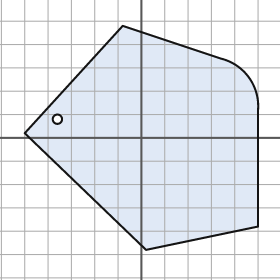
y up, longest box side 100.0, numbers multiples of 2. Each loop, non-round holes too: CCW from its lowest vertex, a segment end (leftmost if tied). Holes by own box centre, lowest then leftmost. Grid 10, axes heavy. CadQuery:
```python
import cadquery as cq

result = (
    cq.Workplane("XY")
    .moveTo(2.0, -48.0)
    .lineTo(50.0, -38.0)
    .lineTo(50.0, 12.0)
    .threePointArc((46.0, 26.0), (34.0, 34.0))
    .lineTo(-8.0, 48.0)
    .lineTo(-50.0, 2.0)
    .close()
    .moveTo(-36.0, 8.0)
    .circle(2.0)
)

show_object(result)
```